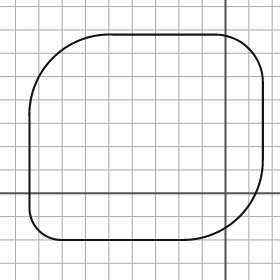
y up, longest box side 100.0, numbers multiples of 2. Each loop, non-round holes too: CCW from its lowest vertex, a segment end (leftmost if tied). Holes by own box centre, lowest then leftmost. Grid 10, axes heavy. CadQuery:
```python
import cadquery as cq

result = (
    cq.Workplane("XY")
    .moveTo(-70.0, -20.0)
    .lineTo(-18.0, -20.0)
    .threePointArc((6.0, -10.0), (16.0, 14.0))
    .lineTo(16.0, 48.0)
    .threePointArc((10.0, 62.0), (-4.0, 68.0))
    .lineTo(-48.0, 68.0)
    .threePointArc((-74.0, 58.0), (-84.0, 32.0))
    .lineTo(-84.0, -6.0)
    .threePointArc((-80.0, -16.0), (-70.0, -20.0))
    .close()
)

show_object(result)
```